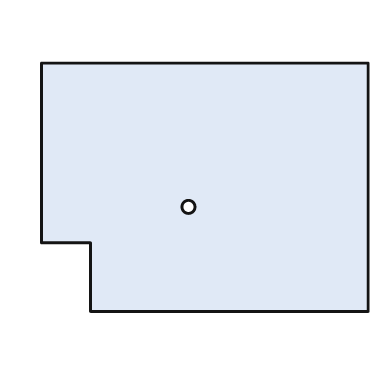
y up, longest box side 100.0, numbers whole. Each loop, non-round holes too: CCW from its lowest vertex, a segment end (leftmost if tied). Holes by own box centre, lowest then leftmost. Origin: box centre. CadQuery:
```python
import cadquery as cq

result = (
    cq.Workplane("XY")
    .moveTo(-35.0, -38.0)
    .lineTo(50.0, -38.0)
    .lineTo(50.0, 38.0)
    .lineTo(-50.0, 38.0)
    .lineTo(-50.0, -17.0)
    .lineTo(-35.0, -17.0)
    .close()
    .moveTo(-5.0, -6.0)
    .circle(2.0)
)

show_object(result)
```